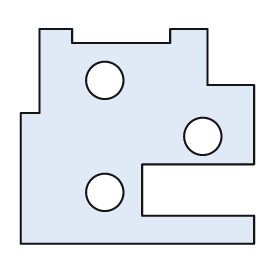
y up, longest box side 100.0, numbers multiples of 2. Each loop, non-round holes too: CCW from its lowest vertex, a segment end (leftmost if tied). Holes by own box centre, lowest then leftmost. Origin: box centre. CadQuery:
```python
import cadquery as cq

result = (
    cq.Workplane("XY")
    .moveTo(-50.0, -46.0)
    .lineTo(50.0, -46.0)
    .lineTo(50.0, -34.0)
    .lineTo(2.0, -34.0)
    .lineTo(2.0, -12.0)
    .lineTo(50.0, -12.0)
    .lineTo(50.0, 22.0)
    .lineTo(30.0, 22.0)
    .lineTo(30.0, 46.0)
    .lineTo(14.0, 46.0)
    .lineTo(14.0, 40.0)
    .lineTo(-28.0, 40.0)
    .lineTo(-28.0, 46.0)
    .lineTo(-42.0, 46.0)
    .lineTo(-42.0, 10.0)
    .lineTo(-50.0, 10.0)
    .close()
    .moveTo(-14.0, -24.0)
    .circle(8.0)
    .moveTo(28.0, 0.0)
    .circle(8.0)
    .moveTo(-14.0, 24.0)
    .circle(8.0)
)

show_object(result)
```